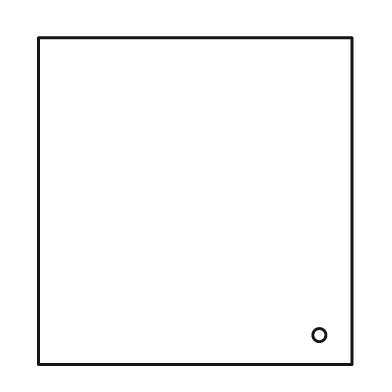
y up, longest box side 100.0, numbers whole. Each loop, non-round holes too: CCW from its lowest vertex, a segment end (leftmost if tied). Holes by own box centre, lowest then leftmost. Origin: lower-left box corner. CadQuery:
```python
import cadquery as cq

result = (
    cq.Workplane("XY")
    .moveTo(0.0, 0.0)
    .lineTo(96.0, 0.0)
    .lineTo(96.0, 100.0)
    .lineTo(0.0, 100.0)
    .close()
    .moveTo(86.0, 9.0)
    .circle(2.0)
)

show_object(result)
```